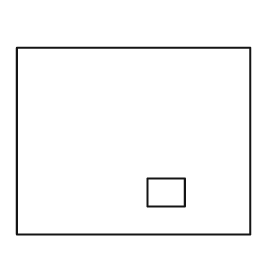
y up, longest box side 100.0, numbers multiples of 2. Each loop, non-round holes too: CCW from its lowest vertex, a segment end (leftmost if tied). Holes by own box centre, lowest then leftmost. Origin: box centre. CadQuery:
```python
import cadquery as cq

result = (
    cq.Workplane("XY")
    .moveTo(-50.0, -40.0)
    .lineTo(50.0, -40.0)
    .lineTo(50.0, 40.0)
    .lineTo(-50.0, 40.0)
    .close()
    .moveTo(6.0, -28.0)
    .lineTo(22.0, -28.0)
    .lineTo(22.0, -16.0)
    .lineTo(6.0, -16.0)
    .close()
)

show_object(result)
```